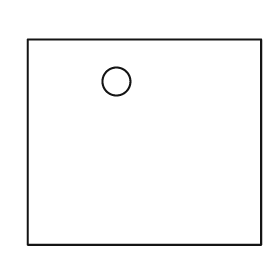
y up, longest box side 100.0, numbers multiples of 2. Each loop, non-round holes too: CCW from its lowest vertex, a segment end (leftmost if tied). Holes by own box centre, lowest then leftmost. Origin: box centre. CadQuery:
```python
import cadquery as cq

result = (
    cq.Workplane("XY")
    .moveTo(-50.0, -44.0)
    .lineTo(50.0, -44.0)
    .lineTo(50.0, 44.0)
    .lineTo(-50.0, 44.0)
    .close()
    .moveTo(-12.0, 26.0)
    .circle(6.0)
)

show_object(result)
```